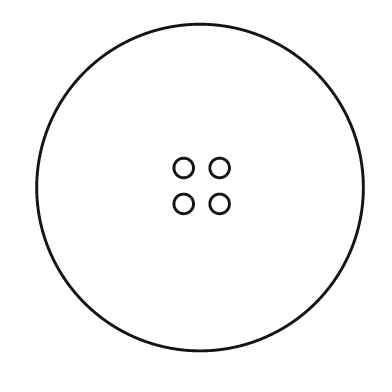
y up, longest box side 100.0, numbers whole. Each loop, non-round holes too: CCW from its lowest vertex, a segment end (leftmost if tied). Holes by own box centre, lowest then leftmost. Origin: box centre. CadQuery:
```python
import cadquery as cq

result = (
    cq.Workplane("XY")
    .moveTo(0.0, 0.0)
    .circle(50.0)
    .moveTo(-5.0, -5.0)
    .circle(3.0)
    .moveTo(6.0, -5.0)
    .circle(3.0)
    .moveTo(-5.0, 6.0)
    .circle(3.0)
    .moveTo(6.0, 6.0)
    .circle(3.0)
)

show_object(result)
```